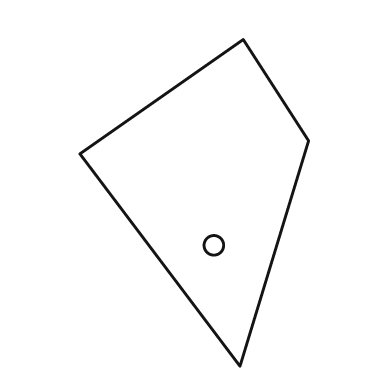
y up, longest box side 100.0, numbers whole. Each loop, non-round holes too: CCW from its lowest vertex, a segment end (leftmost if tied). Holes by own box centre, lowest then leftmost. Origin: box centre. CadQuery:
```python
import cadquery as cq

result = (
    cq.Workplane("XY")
    .moveTo(14.0, -50.0)
    .lineTo(35.0, 19.0)
    .lineTo(15.0, 50.0)
    .lineTo(-35.0, 15.0)
    .close()
    .moveTo(6.0, -13.0)
    .circle(3.0)
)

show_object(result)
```